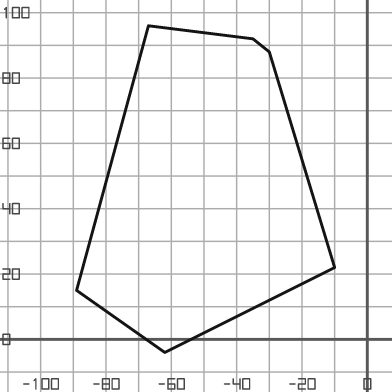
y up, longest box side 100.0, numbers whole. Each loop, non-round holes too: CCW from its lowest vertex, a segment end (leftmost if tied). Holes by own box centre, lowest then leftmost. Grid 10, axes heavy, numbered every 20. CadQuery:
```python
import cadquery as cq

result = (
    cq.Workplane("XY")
    .moveTo(-62.0, -4.0)
    .lineTo(-10.0, 22.0)
    .lineTo(-30.0, 88.0)
    .lineTo(-35.0, 92.0)
    .lineTo(-67.0, 96.0)
    .lineTo(-89.0, 15.0)
    .close()
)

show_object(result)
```